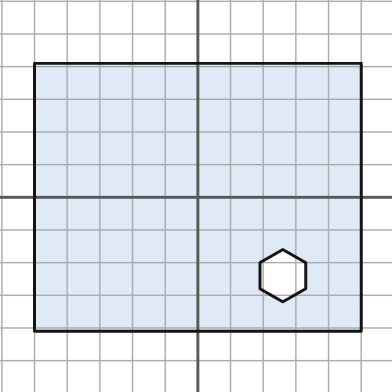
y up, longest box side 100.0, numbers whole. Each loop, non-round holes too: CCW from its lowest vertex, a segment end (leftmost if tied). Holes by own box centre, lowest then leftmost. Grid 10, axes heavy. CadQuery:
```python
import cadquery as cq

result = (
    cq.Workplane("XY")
    .moveTo(-50.0, -41.0)
    .lineTo(50.0, -41.0)
    .lineTo(50.0, 41.0)
    .lineTo(-50.0, 41.0)
    .close()
    .moveTo(26.0, -32.0)
    .lineTo(33.0, -28.0)
    .lineTo(33.0, -20.0)
    .lineTo(26.0, -16.0)
    .lineTo(19.0, -20.0)
    .lineTo(19.0, -28.0)
    .close()
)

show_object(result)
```